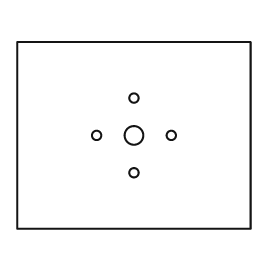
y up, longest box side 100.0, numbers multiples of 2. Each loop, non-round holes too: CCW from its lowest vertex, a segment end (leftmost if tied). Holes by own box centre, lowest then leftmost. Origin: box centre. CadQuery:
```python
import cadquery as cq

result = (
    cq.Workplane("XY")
    .moveTo(-50.0, -40.0)
    .lineTo(50.0, -40.0)
    .lineTo(50.0, 40.0)
    .lineTo(-50.0, 40.0)
    .close()
    .moveTo(0.0, -16.0)
    .circle(2.0)
    .moveTo(-16.0, 0.0)
    .circle(2.0)
    .moveTo(0.0, 0.0)
    .circle(4.0)
    .moveTo(16.0, 0.0)
    .circle(2.0)
    .moveTo(0.0, 16.0)
    .circle(2.0)
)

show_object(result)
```